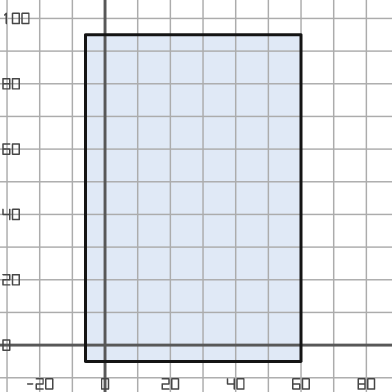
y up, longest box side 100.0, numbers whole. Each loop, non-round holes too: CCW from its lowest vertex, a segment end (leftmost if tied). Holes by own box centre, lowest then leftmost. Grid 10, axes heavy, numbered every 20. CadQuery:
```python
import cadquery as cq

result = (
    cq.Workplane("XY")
    .moveTo(-6.0, -5.0)
    .lineTo(60.0, -5.0)
    .lineTo(60.0, 95.0)
    .lineTo(-6.0, 95.0)
    .close()
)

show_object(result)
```